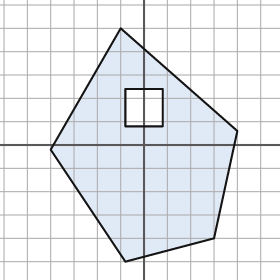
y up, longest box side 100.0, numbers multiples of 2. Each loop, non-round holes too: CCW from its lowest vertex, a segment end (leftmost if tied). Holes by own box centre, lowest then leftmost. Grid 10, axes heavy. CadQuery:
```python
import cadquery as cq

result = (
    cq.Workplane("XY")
    .moveTo(-8.0, -50.0)
    .lineTo(30.0, -40.0)
    .lineTo(40.0, 6.0)
    .lineTo(-10.0, 50.0)
    .lineTo(-40.0, -2.0)
    .close()
    .moveTo(-8.0, 8.0)
    .lineTo(8.0, 8.0)
    .lineTo(8.0, 24.0)
    .lineTo(-8.0, 24.0)
    .close()
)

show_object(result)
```